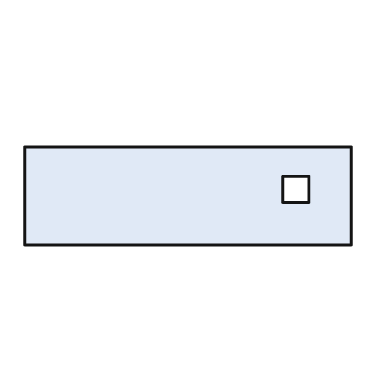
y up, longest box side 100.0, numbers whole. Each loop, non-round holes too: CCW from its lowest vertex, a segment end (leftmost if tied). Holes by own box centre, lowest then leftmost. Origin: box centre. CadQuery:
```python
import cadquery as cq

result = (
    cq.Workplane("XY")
    .moveTo(-50.0, -15.0)
    .lineTo(50.0, -15.0)
    .lineTo(50.0, 15.0)
    .lineTo(-50.0, 15.0)
    .close()
    .moveTo(29.0, -2.0)
    .lineTo(37.0, -2.0)
    .lineTo(37.0, 6.0)
    .lineTo(29.0, 6.0)
    .close()
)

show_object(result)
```